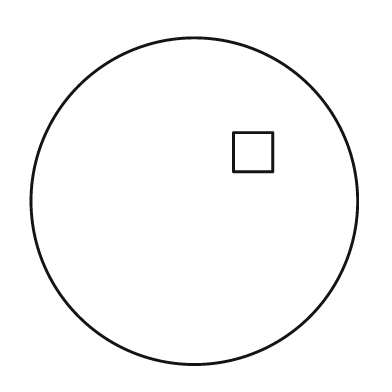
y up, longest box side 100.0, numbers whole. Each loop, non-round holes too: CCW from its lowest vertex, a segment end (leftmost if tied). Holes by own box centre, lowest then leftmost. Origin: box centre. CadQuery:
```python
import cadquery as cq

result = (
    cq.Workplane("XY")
    .moveTo(0.0, 0.0)
    .circle(50.0)
    .moveTo(12.0, 9.0)
    .lineTo(24.0, 9.0)
    .lineTo(24.0, 21.0)
    .lineTo(12.0, 21.0)
    .close()
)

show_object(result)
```